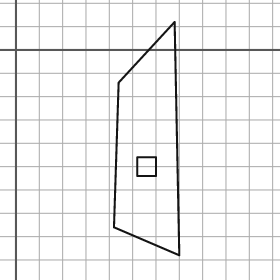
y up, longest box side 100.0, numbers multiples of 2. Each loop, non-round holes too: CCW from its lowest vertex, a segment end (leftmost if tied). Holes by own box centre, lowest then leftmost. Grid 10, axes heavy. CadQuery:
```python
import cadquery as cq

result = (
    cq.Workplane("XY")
    .moveTo(70.0, -88.0)
    .lineTo(68.0, 12.0)
    .lineTo(44.0, -14.0)
    .lineTo(42.0, -76.0)
    .close()
    .moveTo(52.0, -54.0)
    .lineTo(60.0, -54.0)
    .lineTo(60.0, -46.0)
    .lineTo(52.0, -46.0)
    .close()
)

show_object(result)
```